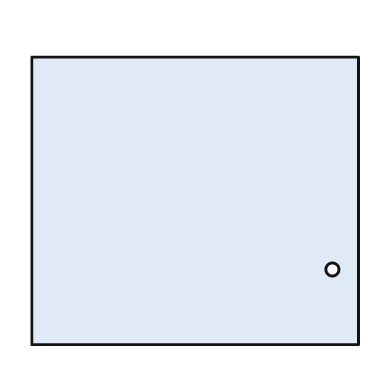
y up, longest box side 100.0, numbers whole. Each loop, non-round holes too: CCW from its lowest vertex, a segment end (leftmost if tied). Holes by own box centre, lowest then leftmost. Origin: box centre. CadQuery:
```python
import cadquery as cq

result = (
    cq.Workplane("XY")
    .moveTo(-50.0, -44.0)
    .lineTo(50.0, -44.0)
    .lineTo(50.0, 44.0)
    .lineTo(-50.0, 44.0)
    .close()
    .moveTo(42.0, -21.0)
    .circle(2.0)
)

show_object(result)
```